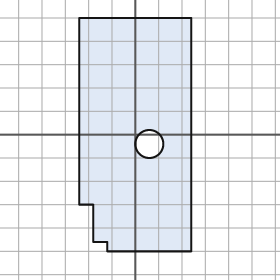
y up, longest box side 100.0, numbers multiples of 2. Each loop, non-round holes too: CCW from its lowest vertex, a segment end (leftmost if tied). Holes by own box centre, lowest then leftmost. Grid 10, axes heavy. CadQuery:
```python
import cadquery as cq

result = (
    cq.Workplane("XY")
    .moveTo(-12.0, -50.0)
    .lineTo(24.0, -50.0)
    .lineTo(24.0, 50.0)
    .lineTo(-24.0, 50.0)
    .lineTo(-24.0, -30.0)
    .lineTo(-18.0, -30.0)
    .lineTo(-18.0, -46.0)
    .lineTo(-12.0, -46.0)
    .close()
    .moveTo(6.0, -4.0)
    .circle(6.0)
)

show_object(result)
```